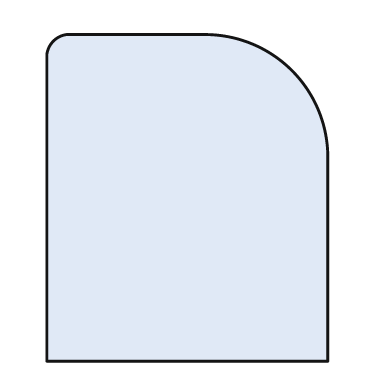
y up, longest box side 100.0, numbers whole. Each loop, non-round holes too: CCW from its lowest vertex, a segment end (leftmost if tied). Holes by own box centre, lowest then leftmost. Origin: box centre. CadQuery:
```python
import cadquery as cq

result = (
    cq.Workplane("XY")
    .moveTo(-43.0, -50.0)
    .lineTo(43.0, -50.0)
    .lineTo(43.0, 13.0)
    .threePointArc((32.0, 39.0), (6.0, 50.0))
    .lineTo(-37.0, 50.0)
    .threePointArc((-41.0, 48.0), (-43.0, 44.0))
    .close()
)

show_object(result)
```